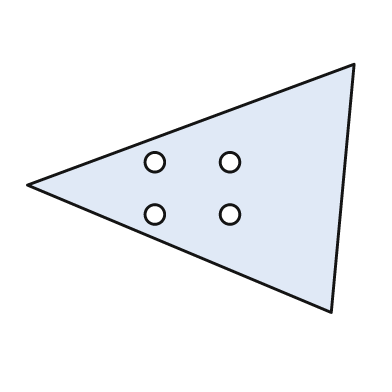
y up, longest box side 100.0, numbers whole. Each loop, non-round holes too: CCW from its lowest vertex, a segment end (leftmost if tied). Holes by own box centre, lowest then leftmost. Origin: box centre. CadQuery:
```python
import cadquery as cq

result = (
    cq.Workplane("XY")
    .moveTo(43.0, -38.0)
    .lineTo(50.0, 38.0)
    .lineTo(-50.0, 1.0)
    .close()
    .moveTo(-11.0, -8.0)
    .circle(3.0)
    .moveTo(12.0, -8.0)
    .circle(3.0)
    .moveTo(-11.0, 8.0)
    .circle(3.0)
    .moveTo(12.0, 8.0)
    .circle(3.0)
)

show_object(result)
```